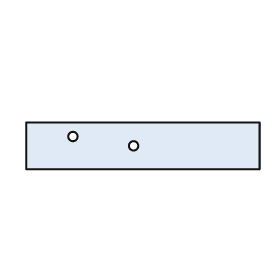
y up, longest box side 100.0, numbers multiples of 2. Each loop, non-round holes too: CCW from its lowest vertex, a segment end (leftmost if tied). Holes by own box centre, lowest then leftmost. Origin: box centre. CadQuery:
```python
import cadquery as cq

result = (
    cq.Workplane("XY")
    .moveTo(-50.0, -10.0)
    .lineTo(50.0, -10.0)
    .lineTo(50.0, 10.0)
    .lineTo(-50.0, 10.0)
    .close()
    .moveTo(-4.0, 0.0)
    .circle(2.0)
    .moveTo(-30.0, 4.0)
    .circle(2.0)
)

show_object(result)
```